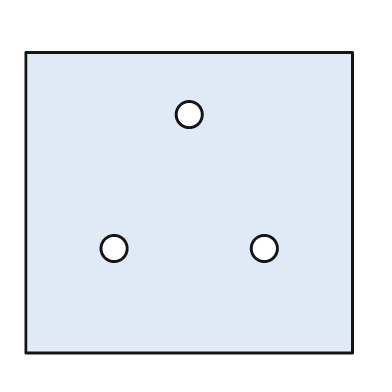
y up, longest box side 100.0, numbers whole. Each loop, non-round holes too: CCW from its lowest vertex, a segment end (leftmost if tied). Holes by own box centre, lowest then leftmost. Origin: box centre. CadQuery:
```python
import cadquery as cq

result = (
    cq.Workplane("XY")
    .moveTo(-50.0, -46.0)
    .lineTo(50.0, -46.0)
    .lineTo(50.0, 46.0)
    .lineTo(-50.0, 46.0)
    .close()
    .moveTo(-23.0, -14.0)
    .circle(4.0)
    .moveTo(23.0, -14.0)
    .circle(4.0)
    .moveTo(0.0, 27.0)
    .circle(4.0)
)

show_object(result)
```